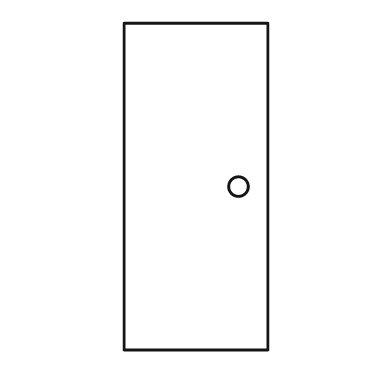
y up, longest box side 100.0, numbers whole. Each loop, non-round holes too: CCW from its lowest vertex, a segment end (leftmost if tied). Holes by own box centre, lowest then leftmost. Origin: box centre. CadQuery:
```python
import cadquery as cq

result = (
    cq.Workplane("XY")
    .moveTo(-22.0, -50.0)
    .lineTo(22.0, -50.0)
    .lineTo(22.0, 50.0)
    .lineTo(-22.0, 50.0)
    .close()
    .moveTo(13.0, 0.0)
    .circle(3.0)
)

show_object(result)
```